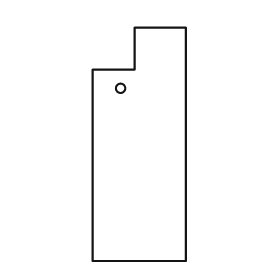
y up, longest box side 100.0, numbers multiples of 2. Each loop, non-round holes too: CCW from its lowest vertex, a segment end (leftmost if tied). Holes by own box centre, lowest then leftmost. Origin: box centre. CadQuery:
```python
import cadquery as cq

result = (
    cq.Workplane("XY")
    .moveTo(-20.0, -50.0)
    .lineTo(20.0, -50.0)
    .lineTo(20.0, 50.0)
    .lineTo(-2.0, 50.0)
    .lineTo(-2.0, 32.0)
    .lineTo(-20.0, 32.0)
    .close()
    .moveTo(-8.0, 24.0)
    .circle(2.0)
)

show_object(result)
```